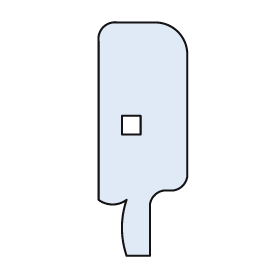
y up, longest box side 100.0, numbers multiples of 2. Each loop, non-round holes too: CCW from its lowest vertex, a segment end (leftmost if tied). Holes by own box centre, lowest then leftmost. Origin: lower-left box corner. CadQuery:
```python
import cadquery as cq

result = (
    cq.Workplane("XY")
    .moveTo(12.0, 0.0)
    .lineTo(22.0, 0.0)
    .lineTo(22.0, 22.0)
    .threePointArc((24.0, 26.0), (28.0, 28.0))
    .lineTo(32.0, 28.0)
    .threePointArc((36.0, 30.0), (38.0, 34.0))
    .lineTo(38.0, 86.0)
    .threePointArc((34.0, 96.0), (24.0, 100.0))
    .lineTo(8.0, 100.0)
    .threePointArc((2.0, 98.0), (0.0, 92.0))
    .lineTo(0.0, 24.0)
    .threePointArc((6.0, 22.0), (12.0, 24.0))
    .threePointArc((10.0, 12.0), (12.0, 0.0))
    .close()
    .moveTo(10.0, 52.0)
    .lineTo(18.0, 52.0)
    .lineTo(18.0, 60.0)
    .lineTo(10.0, 60.0)
    .close()
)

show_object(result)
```